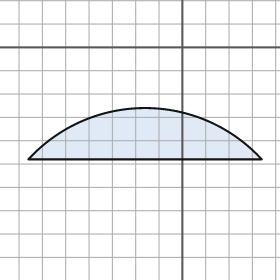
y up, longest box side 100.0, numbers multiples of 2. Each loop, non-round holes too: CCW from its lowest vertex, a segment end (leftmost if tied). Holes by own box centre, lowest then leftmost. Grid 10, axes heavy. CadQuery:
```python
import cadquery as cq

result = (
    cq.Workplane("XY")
    .moveTo(-66.0, -48.0)
    .lineTo(34.0, -48.0)
    .threePointArc((-16.0, -26.0), (-66.0, -48.0))
    .close()
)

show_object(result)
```